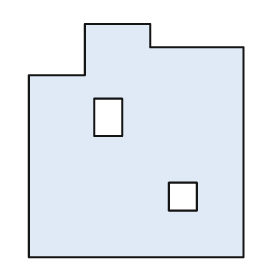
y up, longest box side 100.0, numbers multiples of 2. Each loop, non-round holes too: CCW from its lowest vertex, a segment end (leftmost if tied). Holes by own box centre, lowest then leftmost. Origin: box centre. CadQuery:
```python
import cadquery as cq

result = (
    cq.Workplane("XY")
    .moveTo(-46.0, -50.0)
    .lineTo(46.0, -50.0)
    .lineTo(46.0, 40.0)
    .lineTo(6.0, 40.0)
    .lineTo(6.0, 50.0)
    .lineTo(-22.0, 50.0)
    .lineTo(-22.0, 28.0)
    .lineTo(-46.0, 28.0)
    .close()
    .moveTo(14.0, -30.0)
    .lineTo(26.0, -30.0)
    .lineTo(26.0, -18.0)
    .lineTo(14.0, -18.0)
    .close()
    .moveTo(-18.0, 2.0)
    .lineTo(-6.0, 2.0)
    .lineTo(-6.0, 18.0)
    .lineTo(-18.0, 18.0)
    .close()
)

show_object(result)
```